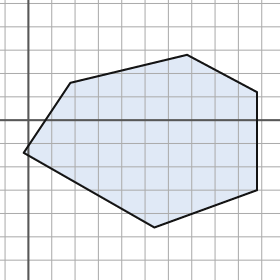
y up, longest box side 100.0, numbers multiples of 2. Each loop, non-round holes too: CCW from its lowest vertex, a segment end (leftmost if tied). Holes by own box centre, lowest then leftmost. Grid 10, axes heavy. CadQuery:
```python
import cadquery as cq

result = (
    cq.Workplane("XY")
    .moveTo(54.0, -46.0)
    .lineTo(98.0, -30.0)
    .lineTo(98.0, 12.0)
    .lineTo(68.0, 28.0)
    .lineTo(18.0, 16.0)
    .lineTo(-2.0, -14.0)
    .close()
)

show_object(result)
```